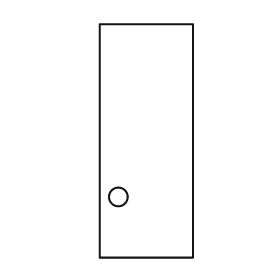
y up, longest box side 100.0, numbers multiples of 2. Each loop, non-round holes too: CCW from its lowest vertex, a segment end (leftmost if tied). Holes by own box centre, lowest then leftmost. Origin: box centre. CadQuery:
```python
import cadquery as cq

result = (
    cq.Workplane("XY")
    .moveTo(-20.0, -50.0)
    .lineTo(20.0, -50.0)
    .lineTo(20.0, 50.0)
    .lineTo(-20.0, 50.0)
    .close()
    .moveTo(-12.0, -24.0)
    .circle(4.0)
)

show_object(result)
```